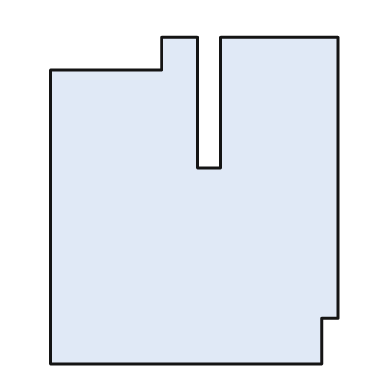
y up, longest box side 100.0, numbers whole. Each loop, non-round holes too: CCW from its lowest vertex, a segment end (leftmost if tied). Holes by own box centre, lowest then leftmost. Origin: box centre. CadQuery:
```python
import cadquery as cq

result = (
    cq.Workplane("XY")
    .moveTo(-44.0, -50.0)
    .lineTo(39.0, -50.0)
    .lineTo(39.0, -36.0)
    .lineTo(44.0, -36.0)
    .lineTo(44.0, 50.0)
    .lineTo(8.0, 50.0)
    .lineTo(8.0, 10.0)
    .lineTo(1.0, 10.0)
    .lineTo(1.0, 50.0)
    .lineTo(-10.0, 50.0)
    .lineTo(-10.0, 40.0)
    .lineTo(-44.0, 40.0)
    .close()
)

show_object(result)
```